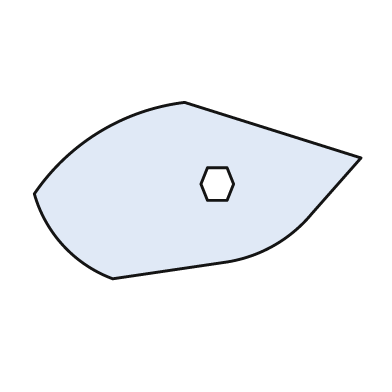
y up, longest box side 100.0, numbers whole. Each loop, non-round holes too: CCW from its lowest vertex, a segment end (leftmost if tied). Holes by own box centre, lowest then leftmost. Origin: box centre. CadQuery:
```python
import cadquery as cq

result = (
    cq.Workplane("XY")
    .moveTo(-26.0, -27.0)
    .lineTo(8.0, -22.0)
    .threePointArc((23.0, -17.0), (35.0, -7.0))
    .lineTo(50.0, 10.0)
    .lineTo(-4.0, 27.0)
    .threePointArc((-30.0, 18.0), (-50.0, -1.0))
    .threePointArc((-41.0, -17.0), (-26.0, -27.0))
    .close()
    .moveTo(3.0, -3.0)
    .lineTo(9.0, -3.0)
    .lineTo(11.0, 2.0)
    .lineTo(9.0, 7.0)
    .lineTo(3.0, 7.0)
    .lineTo(1.0, 2.0)
    .close()
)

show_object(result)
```